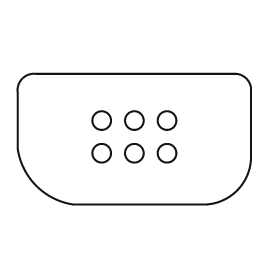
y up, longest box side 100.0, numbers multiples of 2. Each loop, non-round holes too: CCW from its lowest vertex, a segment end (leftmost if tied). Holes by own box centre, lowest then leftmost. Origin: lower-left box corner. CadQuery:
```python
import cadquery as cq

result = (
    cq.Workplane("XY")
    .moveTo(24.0, 0.0)
    .lineTo(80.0, 0.0)
    .threePointArc((94.0, 6.0), (100.0, 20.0))
    .lineTo(100.0, 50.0)
    .threePointArc((98.0, 54.0), (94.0, 56.0))
    .lineTo(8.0, 56.0)
    .threePointArc((2.0, 54.0), (0.0, 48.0))
    .lineTo(0.0, 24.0)
    .threePointArc((8.0, 8.0), (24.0, 0.0))
    .close()
    .moveTo(36.0, 22.0)
    .circle(4.0)
    .moveTo(50.0, 22.0)
    .circle(4.0)
    .moveTo(64.0, 22.0)
    .circle(4.0)
    .moveTo(36.0, 36.0)
    .circle(4.0)
    .moveTo(50.0, 36.0)
    .circle(4.0)
    .moveTo(64.0, 36.0)
    .circle(4.0)
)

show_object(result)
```